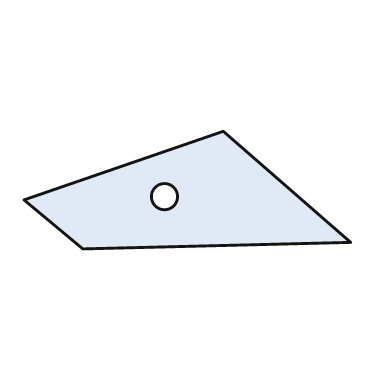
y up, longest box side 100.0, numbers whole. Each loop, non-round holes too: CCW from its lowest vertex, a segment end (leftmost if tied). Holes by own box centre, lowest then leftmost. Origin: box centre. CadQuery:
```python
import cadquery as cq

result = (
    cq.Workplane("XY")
    .moveTo(-32.0, -18.0)
    .lineTo(50.0, -16.0)
    .lineTo(11.0, 18.0)
    .lineTo(-50.0, -3.0)
    .close()
    .moveTo(-7.0, -2.0)
    .circle(4.0)
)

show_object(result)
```